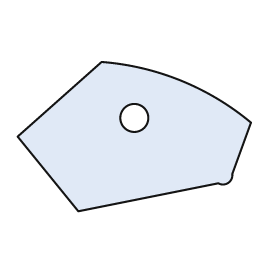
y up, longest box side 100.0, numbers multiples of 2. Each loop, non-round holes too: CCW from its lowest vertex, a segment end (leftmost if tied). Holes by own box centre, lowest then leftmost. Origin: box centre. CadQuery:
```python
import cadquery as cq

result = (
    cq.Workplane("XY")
    .moveTo(-24.0, -32.0)
    .lineTo(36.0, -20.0)
    .threePointArc((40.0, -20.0), (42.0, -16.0))
    .lineTo(50.0, 6.0)
    .threePointArc((20.0, 24.0), (-14.0, 32.0))
    .lineTo(-50.0, 0.0)
    .close()
    .moveTo(0.0, 8.0)
    .circle(6.0)
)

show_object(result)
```